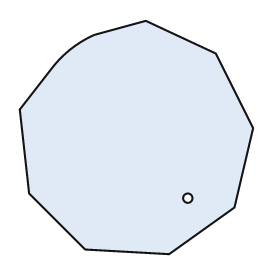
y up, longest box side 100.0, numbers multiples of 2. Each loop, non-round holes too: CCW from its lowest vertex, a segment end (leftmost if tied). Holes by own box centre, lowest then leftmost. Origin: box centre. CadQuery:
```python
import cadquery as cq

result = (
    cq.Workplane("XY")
    .moveTo(14.0, -50.0)
    .lineTo(42.0, -30.0)
    .lineTo(50.0, 4.0)
    .lineTo(34.0, 36.0)
    .lineTo(4.0, 50.0)
    .lineTo(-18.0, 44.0)
    .threePointArc((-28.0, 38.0), (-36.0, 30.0))
    .lineTo(-50.0, 12.0)
    .lineTo(-46.0, -24.0)
    .lineTo(-22.0, -48.0)
    .close()
    .moveTo(22.0, -26.0)
    .circle(2.0)
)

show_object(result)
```